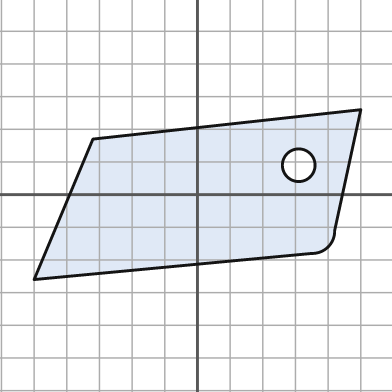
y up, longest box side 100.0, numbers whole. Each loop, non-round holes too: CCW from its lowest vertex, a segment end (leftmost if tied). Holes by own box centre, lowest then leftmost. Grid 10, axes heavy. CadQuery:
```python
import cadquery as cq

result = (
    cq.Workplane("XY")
    .moveTo(-50.0, -26.0)
    .lineTo(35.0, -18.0)
    .threePointArc((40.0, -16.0), (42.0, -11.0))
    .lineTo(50.0, 26.0)
    .lineTo(-32.0, 17.0)
    .close()
    .moveTo(31.0, 9.0)
    .circle(5.0)
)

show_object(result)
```